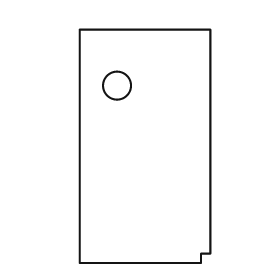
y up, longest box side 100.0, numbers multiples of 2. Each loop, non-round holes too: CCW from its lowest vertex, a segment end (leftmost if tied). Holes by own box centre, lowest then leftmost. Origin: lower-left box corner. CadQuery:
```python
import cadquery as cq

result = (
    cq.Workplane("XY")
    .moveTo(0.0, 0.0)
    .lineTo(52.0, 0.0)
    .lineTo(52.0, 4.0)
    .lineTo(56.0, 4.0)
    .lineTo(56.0, 100.0)
    .lineTo(0.0, 100.0)
    .close()
    .moveTo(16.0, 76.0)
    .circle(6.0)
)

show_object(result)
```